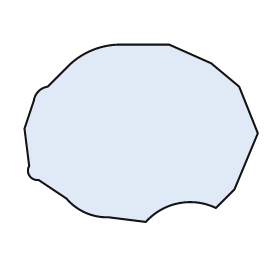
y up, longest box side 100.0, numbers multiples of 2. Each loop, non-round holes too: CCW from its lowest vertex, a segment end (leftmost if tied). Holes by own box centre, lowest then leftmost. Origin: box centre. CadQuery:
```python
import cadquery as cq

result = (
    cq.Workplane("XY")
    .moveTo(2.0, -38.0)
    .threePointArc((16.0, -30.0), (32.0, -32.0))
    .lineTo(40.0, -24.0)
    .lineTo(50.0, 0.0)
    .lineTo(42.0, 20.0)
    .lineTo(30.0, 30.0)
    .lineTo(12.0, 38.0)
    .lineTo(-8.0, 38.0)
    .threePointArc((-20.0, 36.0), (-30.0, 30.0))
    .lineTo(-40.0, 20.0)
    .threePointArc((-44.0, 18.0), (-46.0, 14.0))
    .lineTo(-50.0, 2.0)
    .lineTo(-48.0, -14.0)
    .threePointArc((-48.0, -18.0), (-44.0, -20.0))
    .lineTo(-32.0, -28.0)
    .threePointArc((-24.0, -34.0), (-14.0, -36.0))
    .close()
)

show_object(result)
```